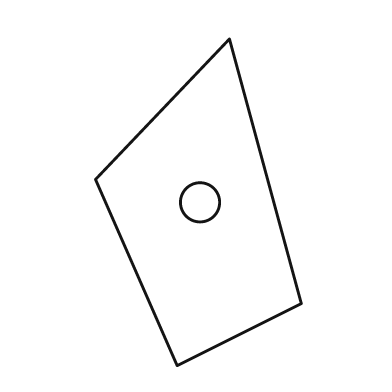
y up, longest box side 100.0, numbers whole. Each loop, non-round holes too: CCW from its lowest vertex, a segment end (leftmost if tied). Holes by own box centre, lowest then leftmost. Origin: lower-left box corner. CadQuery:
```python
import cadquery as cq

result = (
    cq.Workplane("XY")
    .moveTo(25.0, 0.0)
    .lineTo(63.0, 19.0)
    .lineTo(41.0, 100.0)
    .lineTo(0.0, 57.0)
    .close()
    .moveTo(32.0, 50.0)
    .circle(6.0)
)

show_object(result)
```